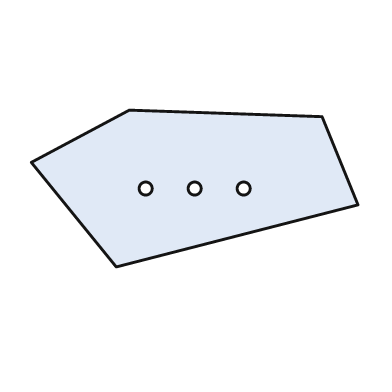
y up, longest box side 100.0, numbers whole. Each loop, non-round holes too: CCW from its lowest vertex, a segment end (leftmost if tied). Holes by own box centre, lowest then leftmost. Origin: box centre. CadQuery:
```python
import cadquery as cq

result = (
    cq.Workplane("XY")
    .moveTo(-24.0, -24.0)
    .lineTo(50.0, -5.0)
    .lineTo(39.0, 22.0)
    .lineTo(-20.0, 24.0)
    .lineTo(-50.0, 8.0)
    .close()
    .moveTo(-15.0, 0.0)
    .circle(2.0)
    .moveTo(0.0, 0.0)
    .circle(2.0)
    .moveTo(15.0, 0.0)
    .circle(2.0)
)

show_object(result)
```